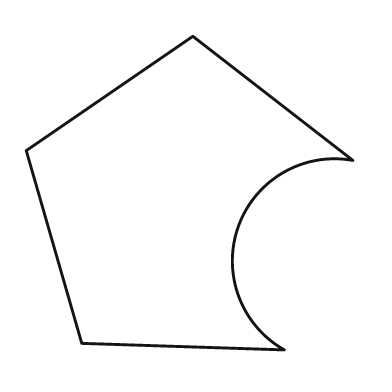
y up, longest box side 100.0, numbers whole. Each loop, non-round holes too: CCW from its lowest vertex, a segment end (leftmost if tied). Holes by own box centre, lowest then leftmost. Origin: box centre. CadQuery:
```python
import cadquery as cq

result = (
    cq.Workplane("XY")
    .moveTo(29.0, -48.0)
    .threePointArc((15.0, -10.0), (50.0, 10.0))
    .lineTo(1.0, 48.0)
    .lineTo(-50.0, 13.0)
    .lineTo(-33.0, -46.0)
    .close()
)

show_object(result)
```